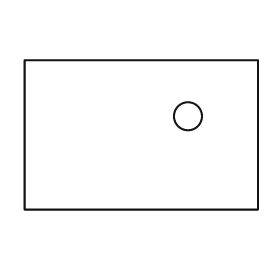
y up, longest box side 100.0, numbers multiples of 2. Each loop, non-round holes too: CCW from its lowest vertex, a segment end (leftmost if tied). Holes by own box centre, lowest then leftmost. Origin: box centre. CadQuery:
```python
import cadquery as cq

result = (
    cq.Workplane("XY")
    .moveTo(-50.0, -32.0)
    .lineTo(50.0, -32.0)
    .lineTo(50.0, 32.0)
    .lineTo(-50.0, 32.0)
    .close()
    .moveTo(20.0, 8.0)
    .circle(6.0)
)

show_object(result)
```